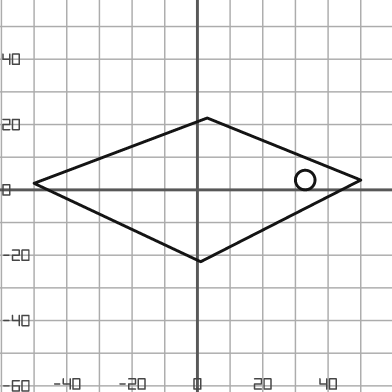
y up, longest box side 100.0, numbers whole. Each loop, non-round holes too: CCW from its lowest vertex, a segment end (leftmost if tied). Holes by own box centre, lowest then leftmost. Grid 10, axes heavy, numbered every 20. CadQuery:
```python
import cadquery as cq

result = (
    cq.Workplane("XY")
    .moveTo(1.0, -22.0)
    .lineTo(50.0, 3.0)
    .lineTo(3.0, 22.0)
    .lineTo(-50.0, 2.0)
    .close()
    .moveTo(33.0, 3.0)
    .circle(3.0)
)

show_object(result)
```